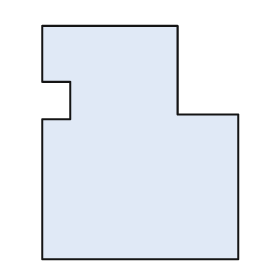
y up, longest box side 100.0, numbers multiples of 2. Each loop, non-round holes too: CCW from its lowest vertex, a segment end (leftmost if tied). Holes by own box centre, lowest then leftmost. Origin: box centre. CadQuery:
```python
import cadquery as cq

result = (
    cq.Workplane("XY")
    .moveTo(-42.0, -50.0)
    .lineTo(42.0, -50.0)
    .lineTo(42.0, 12.0)
    .lineTo(16.0, 12.0)
    .lineTo(16.0, 50.0)
    .lineTo(-42.0, 50.0)
    .lineTo(-42.0, 26.0)
    .lineTo(-30.0, 26.0)
    .lineTo(-30.0, 10.0)
    .lineTo(-42.0, 10.0)
    .close()
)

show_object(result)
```